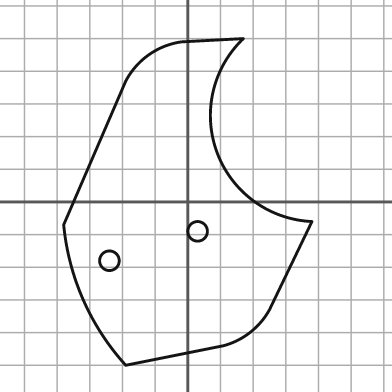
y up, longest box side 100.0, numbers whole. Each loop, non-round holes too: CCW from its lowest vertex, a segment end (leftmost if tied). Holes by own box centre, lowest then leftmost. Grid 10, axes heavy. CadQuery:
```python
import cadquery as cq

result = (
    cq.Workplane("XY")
    .moveTo(-19.0, -50.0)
    .lineTo(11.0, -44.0)
    .threePointArc((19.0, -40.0), (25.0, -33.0))
    .lineTo(38.0, -6.0)
    .threePointArc((9.0, 15.0), (17.0, 50.0))
    .lineTo(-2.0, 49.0)
    .threePointArc((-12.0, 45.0), (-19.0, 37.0))
    .lineTo(-38.0, -7.0)
    .threePointArc((-32.0, -30.0), (-19.0, -50.0))
    .close()
    .moveTo(-24.0, -18.0)
    .circle(3.0)
    .moveTo(3.0, -9.0)
    .circle(3.0)
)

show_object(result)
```